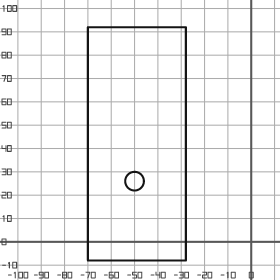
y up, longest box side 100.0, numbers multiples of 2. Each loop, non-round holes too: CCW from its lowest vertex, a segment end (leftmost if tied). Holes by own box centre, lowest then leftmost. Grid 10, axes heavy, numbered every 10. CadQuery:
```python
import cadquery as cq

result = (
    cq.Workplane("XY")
    .moveTo(-70.0, -8.0)
    .lineTo(-28.0, -8.0)
    .lineTo(-28.0, 92.0)
    .lineTo(-70.0, 92.0)
    .close()
    .moveTo(-50.0, 26.0)
    .circle(4.0)
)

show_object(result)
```